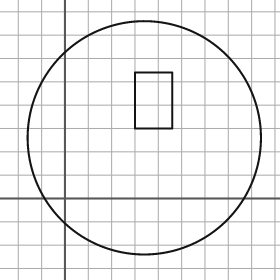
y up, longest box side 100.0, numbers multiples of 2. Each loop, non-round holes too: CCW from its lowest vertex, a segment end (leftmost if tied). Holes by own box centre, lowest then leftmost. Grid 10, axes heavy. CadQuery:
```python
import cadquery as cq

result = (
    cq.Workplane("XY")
    .moveTo(34.0, 26.0)
    .circle(50.0)
    .moveTo(30.0, 30.0)
    .lineTo(46.0, 30.0)
    .lineTo(46.0, 54.0)
    .lineTo(30.0, 54.0)
    .close()
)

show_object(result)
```